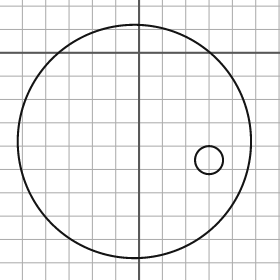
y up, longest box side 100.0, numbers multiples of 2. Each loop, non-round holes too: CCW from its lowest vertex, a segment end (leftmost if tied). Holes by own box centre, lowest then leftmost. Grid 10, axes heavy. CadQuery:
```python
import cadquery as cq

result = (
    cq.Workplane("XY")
    .moveTo(-2.0, -38.0)
    .circle(50.0)
    .moveTo(30.0, -46.0)
    .circle(6.0)
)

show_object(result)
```